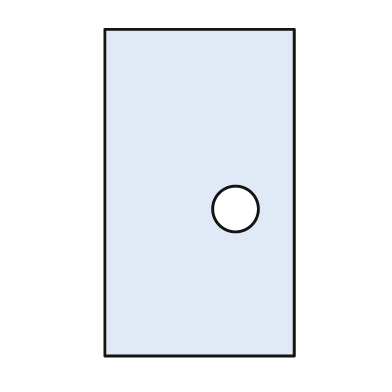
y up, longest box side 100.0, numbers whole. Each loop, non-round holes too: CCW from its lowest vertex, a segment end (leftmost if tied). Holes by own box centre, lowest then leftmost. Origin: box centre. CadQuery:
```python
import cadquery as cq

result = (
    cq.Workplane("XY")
    .moveTo(-29.0, -50.0)
    .lineTo(29.0, -50.0)
    .lineTo(29.0, 50.0)
    .lineTo(-29.0, 50.0)
    .close()
    .moveTo(11.0, -5.0)
    .circle(7.0)
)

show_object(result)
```